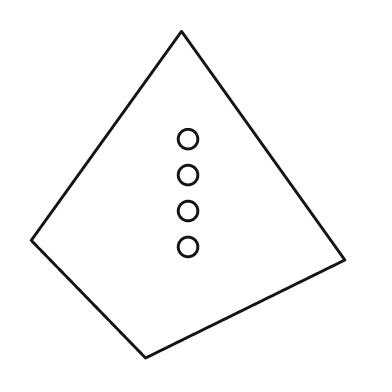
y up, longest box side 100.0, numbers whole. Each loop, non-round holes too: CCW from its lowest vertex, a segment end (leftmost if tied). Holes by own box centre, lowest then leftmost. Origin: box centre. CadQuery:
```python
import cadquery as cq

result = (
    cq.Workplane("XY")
    .moveTo(-13.0, -50.0)
    .lineTo(48.0, -20.0)
    .lineTo(-2.0, 50.0)
    .lineTo(-48.0, -14.0)
    .close()
    .moveTo(0.0, -16.0)
    .circle(3.0)
    .moveTo(0.0, -5.0)
    .circle(3.0)
    .moveTo(0.0, 6.0)
    .circle(3.0)
    .moveTo(0.0, 17.0)
    .circle(3.0)
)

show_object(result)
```